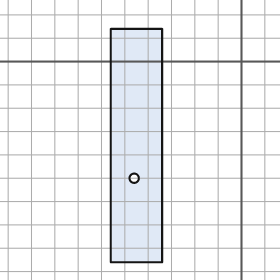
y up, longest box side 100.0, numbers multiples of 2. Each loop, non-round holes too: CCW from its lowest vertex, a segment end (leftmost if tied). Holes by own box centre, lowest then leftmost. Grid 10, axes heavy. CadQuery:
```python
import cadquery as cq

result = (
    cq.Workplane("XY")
    .moveTo(-56.0, -86.0)
    .lineTo(-34.0, -86.0)
    .lineTo(-34.0, 14.0)
    .lineTo(-56.0, 14.0)
    .close()
    .moveTo(-46.0, -50.0)
    .circle(2.0)
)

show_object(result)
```